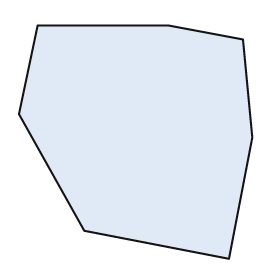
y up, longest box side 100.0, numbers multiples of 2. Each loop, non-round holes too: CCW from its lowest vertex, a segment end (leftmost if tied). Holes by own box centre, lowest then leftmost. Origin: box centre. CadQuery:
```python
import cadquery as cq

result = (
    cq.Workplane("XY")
    .moveTo(40.0, -50.0)
    .lineTo(50.0, 2.0)
    .lineTo(46.0, 44.0)
    .lineTo(14.0, 50.0)
    .lineTo(-42.0, 50.0)
    .lineTo(-50.0, 12.0)
    .lineTo(-22.0, -38.0)
    .close()
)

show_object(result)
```